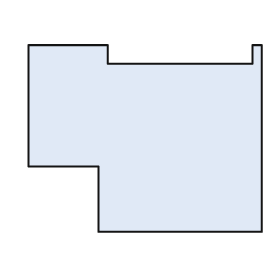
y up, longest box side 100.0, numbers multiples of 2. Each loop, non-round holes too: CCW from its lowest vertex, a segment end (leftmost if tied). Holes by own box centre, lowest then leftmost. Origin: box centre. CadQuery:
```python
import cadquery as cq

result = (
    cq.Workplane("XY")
    .moveTo(-20.0, -40.0)
    .lineTo(50.0, -40.0)
    .lineTo(50.0, 40.0)
    .lineTo(46.0, 40.0)
    .lineTo(46.0, 32.0)
    .lineTo(-16.0, 32.0)
    .lineTo(-16.0, 40.0)
    .lineTo(-50.0, 40.0)
    .lineTo(-50.0, -12.0)
    .lineTo(-20.0, -12.0)
    .close()
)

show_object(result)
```